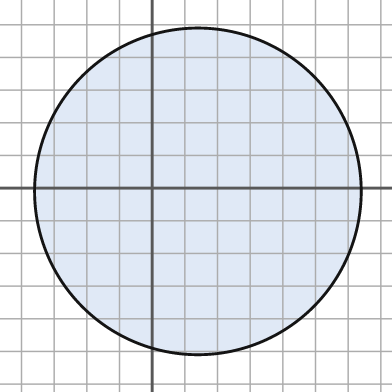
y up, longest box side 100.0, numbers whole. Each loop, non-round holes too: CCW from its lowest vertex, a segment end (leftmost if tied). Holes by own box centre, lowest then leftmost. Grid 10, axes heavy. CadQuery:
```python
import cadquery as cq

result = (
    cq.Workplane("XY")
    .moveTo(14.0, -1.0)
    .circle(50.0)
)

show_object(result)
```